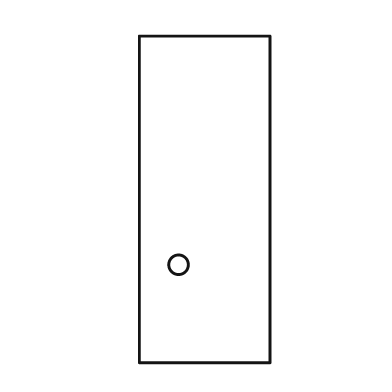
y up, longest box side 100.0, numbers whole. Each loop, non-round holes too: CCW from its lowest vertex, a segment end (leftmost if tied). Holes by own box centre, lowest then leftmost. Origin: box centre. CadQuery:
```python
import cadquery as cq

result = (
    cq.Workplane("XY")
    .moveTo(-20.0, -50.0)
    .lineTo(20.0, -50.0)
    .lineTo(20.0, 50.0)
    .lineTo(-20.0, 50.0)
    .close()
    .moveTo(-8.0, -20.0)
    .circle(3.0)
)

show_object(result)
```